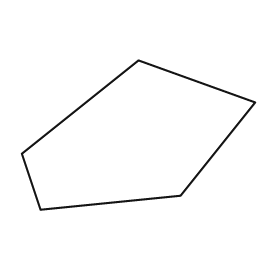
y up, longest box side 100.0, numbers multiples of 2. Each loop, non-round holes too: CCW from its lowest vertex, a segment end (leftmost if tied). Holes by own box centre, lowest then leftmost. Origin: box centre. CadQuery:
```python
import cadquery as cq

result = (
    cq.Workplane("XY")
    .moveTo(-42.0, -32.0)
    .lineTo(18.0, -26.0)
    .lineTo(50.0, 14.0)
    .lineTo(0.0, 32.0)
    .lineTo(-50.0, -8.0)
    .close()
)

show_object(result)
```